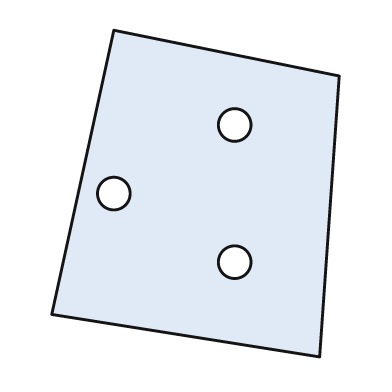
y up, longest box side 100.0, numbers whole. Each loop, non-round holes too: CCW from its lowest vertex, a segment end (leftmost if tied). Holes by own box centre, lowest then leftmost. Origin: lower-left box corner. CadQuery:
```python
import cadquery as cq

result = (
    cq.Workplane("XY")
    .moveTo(82.0, 0.0)
    .lineTo(88.0, 86.0)
    .lineTo(19.0, 100.0)
    .lineTo(0.0, 13.0)
    .close()
    .moveTo(56.0, 29.0)
    .circle(5.0)
    .moveTo(19.0, 50.0)
    .circle(5.0)
    .moveTo(56.0, 71.0)
    .circle(5.0)
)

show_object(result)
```